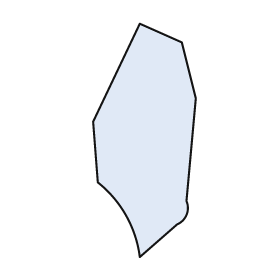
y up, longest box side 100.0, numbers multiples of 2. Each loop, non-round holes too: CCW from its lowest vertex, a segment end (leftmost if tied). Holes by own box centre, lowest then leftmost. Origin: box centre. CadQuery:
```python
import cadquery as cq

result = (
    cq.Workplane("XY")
    .moveTo(-2.0, -50.0)
    .lineTo(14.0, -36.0)
    .threePointArc((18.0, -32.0), (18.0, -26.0))
    .lineTo(22.0, 18.0)
    .lineTo(16.0, 42.0)
    .lineTo(-2.0, 50.0)
    .lineTo(-22.0, 8.0)
    .lineTo(-20.0, -18.0)
    .threePointArc((-8.0, -32.0), (-2.0, -50.0))
    .close()
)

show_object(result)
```